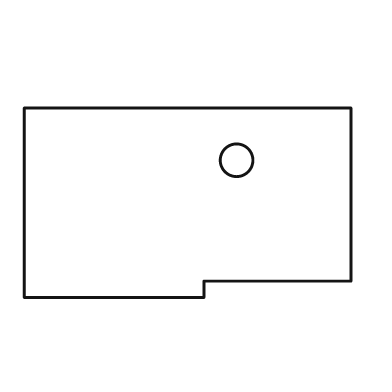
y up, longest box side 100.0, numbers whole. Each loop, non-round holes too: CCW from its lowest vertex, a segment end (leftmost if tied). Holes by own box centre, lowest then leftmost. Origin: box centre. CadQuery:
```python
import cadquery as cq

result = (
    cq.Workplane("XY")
    .moveTo(-50.0, -29.0)
    .lineTo(5.0, -29.0)
    .lineTo(5.0, -24.0)
    .lineTo(50.0, -24.0)
    .lineTo(50.0, 29.0)
    .lineTo(-50.0, 29.0)
    .close()
    .moveTo(15.0, 13.0)
    .circle(5.0)
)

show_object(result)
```